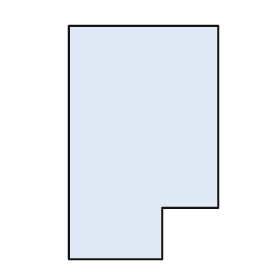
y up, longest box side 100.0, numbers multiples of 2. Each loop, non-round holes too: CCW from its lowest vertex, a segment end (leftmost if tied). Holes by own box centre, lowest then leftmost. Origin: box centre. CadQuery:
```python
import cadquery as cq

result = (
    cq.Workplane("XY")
    .moveTo(-32.0, -50.0)
    .lineTo(8.0, -50.0)
    .lineTo(8.0, -28.0)
    .lineTo(32.0, -28.0)
    .lineTo(32.0, 50.0)
    .lineTo(-32.0, 50.0)
    .close()
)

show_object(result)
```